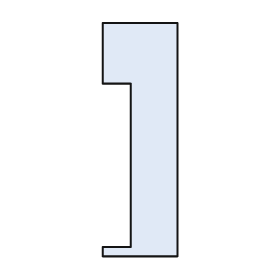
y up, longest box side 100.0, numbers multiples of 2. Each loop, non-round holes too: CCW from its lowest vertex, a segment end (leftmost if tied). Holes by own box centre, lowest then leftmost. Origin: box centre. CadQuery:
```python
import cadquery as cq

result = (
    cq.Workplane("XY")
    .moveTo(-16.0, -50.0)
    .lineTo(16.0, -50.0)
    .lineTo(16.0, 50.0)
    .lineTo(-16.0, 50.0)
    .lineTo(-16.0, 24.0)
    .lineTo(-4.0, 24.0)
    .lineTo(-4.0, -46.0)
    .lineTo(-16.0, -46.0)
    .close()
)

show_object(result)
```